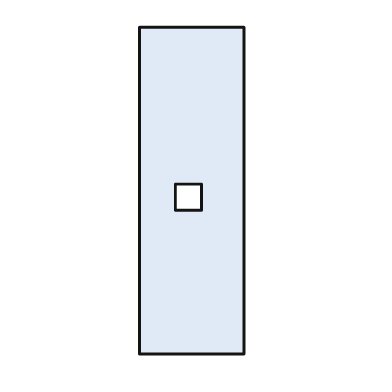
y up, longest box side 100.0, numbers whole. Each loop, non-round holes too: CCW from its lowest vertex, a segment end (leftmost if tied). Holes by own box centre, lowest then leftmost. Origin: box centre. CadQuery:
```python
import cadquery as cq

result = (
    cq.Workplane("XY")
    .moveTo(-16.0, -50.0)
    .lineTo(16.0, -50.0)
    .lineTo(16.0, 50.0)
    .lineTo(-16.0, 50.0)
    .close()
    .moveTo(-5.0, -6.0)
    .lineTo(3.0, -6.0)
    .lineTo(3.0, 2.0)
    .lineTo(-5.0, 2.0)
    .close()
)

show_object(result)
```